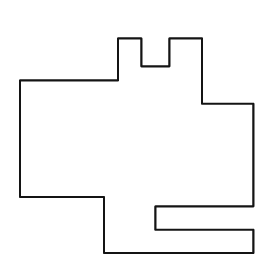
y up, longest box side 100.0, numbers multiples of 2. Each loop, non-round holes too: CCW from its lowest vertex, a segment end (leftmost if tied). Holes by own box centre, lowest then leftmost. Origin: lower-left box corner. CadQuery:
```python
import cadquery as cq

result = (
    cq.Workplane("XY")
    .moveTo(36.0, 0.0)
    .lineTo(100.0, 0.0)
    .lineTo(100.0, 10.0)
    .lineTo(58.0, 10.0)
    .lineTo(58.0, 20.0)
    .lineTo(100.0, 20.0)
    .lineTo(100.0, 64.0)
    .lineTo(78.0, 64.0)
    .lineTo(78.0, 92.0)
    .lineTo(64.0, 92.0)
    .lineTo(64.0, 80.0)
    .lineTo(52.0, 80.0)
    .lineTo(52.0, 92.0)
    .lineTo(42.0, 92.0)
    .lineTo(42.0, 74.0)
    .lineTo(0.0, 74.0)
    .lineTo(0.0, 24.0)
    .lineTo(36.0, 24.0)
    .close()
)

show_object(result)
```